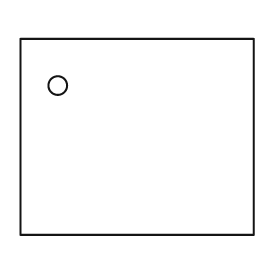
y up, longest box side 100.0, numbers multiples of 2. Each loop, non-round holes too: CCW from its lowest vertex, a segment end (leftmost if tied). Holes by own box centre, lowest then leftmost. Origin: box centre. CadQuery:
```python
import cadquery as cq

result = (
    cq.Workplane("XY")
    .moveTo(-50.0, -42.0)
    .lineTo(50.0, -42.0)
    .lineTo(50.0, 42.0)
    .lineTo(-50.0, 42.0)
    .close()
    .moveTo(-34.0, 22.0)
    .circle(4.0)
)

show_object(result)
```